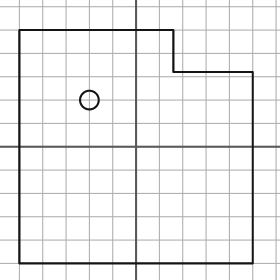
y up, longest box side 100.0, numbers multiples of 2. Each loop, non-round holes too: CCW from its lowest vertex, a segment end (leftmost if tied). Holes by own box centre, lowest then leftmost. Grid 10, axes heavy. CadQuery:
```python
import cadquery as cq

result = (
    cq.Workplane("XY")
    .moveTo(-50.0, -50.0)
    .lineTo(50.0, -50.0)
    .lineTo(50.0, 32.0)
    .lineTo(16.0, 32.0)
    .lineTo(16.0, 50.0)
    .lineTo(-50.0, 50.0)
    .close()
    .moveTo(-20.0, 20.0)
    .circle(4.0)
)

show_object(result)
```